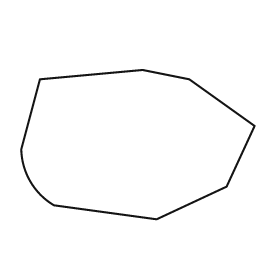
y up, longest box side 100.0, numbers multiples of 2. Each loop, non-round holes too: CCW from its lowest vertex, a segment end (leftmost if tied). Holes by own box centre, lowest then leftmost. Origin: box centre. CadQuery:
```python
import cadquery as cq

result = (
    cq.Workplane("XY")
    .moveTo(8.0, -32.0)
    .lineTo(38.0, -18.0)
    .lineTo(50.0, 8.0)
    .lineTo(22.0, 28.0)
    .lineTo(2.0, 32.0)
    .lineTo(-42.0, 28.0)
    .lineTo(-50.0, -2.0)
    .threePointArc((-46.0, -16.0), (-36.0, -26.0))
    .close()
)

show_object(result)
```